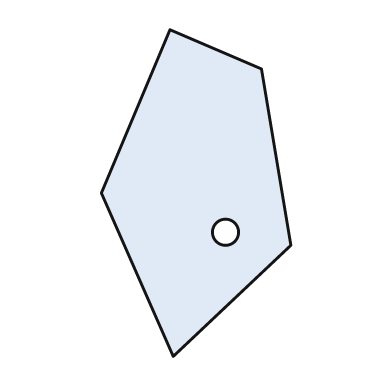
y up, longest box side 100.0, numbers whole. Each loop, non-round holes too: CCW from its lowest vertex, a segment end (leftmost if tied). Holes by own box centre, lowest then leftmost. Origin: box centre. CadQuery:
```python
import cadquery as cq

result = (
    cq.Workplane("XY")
    .moveTo(-7.0, -50.0)
    .lineTo(29.0, -16.0)
    .lineTo(20.0, 38.0)
    .lineTo(-8.0, 50.0)
    .lineTo(-29.0, 0.0)
    .close()
    .moveTo(9.0, -12.0)
    .circle(4.0)
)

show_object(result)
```